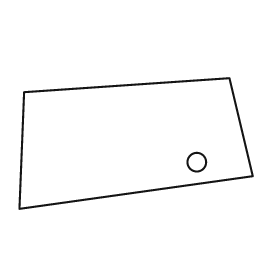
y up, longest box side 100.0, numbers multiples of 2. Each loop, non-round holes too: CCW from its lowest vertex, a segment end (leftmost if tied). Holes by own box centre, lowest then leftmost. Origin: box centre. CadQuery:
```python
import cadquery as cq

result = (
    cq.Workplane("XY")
    .moveTo(-50.0, -28.0)
    .lineTo(50.0, -14.0)
    .lineTo(40.0, 28.0)
    .lineTo(-48.0, 22.0)
    .close()
    .moveTo(26.0, -8.0)
    .circle(4.0)
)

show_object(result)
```